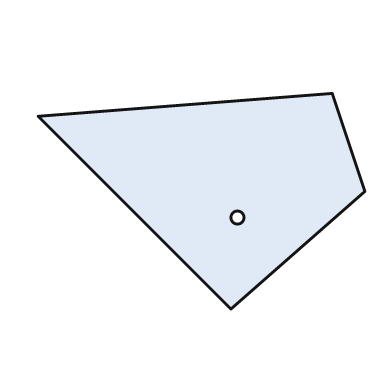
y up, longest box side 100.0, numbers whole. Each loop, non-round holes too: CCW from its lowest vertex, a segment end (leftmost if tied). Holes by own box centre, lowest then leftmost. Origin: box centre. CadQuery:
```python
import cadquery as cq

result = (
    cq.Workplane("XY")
    .moveTo(9.0, -33.0)
    .lineTo(50.0, 3.0)
    .lineTo(40.0, 33.0)
    .lineTo(-50.0, 26.0)
    .close()
    .moveTo(11.0, -5.0)
    .circle(2.0)
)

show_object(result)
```